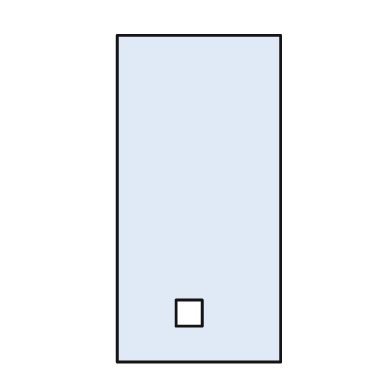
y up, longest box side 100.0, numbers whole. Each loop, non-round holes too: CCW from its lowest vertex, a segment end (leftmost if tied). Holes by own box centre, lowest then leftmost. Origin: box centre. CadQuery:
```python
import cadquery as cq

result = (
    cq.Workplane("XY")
    .moveTo(-25.0, -50.0)
    .lineTo(25.0, -50.0)
    .lineTo(25.0, 50.0)
    .lineTo(-25.0, 50.0)
    .close()
    .moveTo(-7.0, -39.0)
    .lineTo(1.0, -39.0)
    .lineTo(1.0, -31.0)
    .lineTo(-7.0, -31.0)
    .close()
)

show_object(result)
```